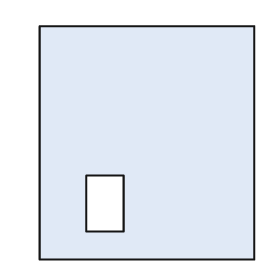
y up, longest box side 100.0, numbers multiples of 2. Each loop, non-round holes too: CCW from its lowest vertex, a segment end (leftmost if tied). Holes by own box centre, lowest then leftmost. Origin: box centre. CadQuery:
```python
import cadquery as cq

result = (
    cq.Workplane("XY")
    .moveTo(-46.0, -50.0)
    .lineTo(46.0, -50.0)
    .lineTo(46.0, 50.0)
    .lineTo(-46.0, 50.0)
    .close()
    .moveTo(-26.0, -38.0)
    .lineTo(-10.0, -38.0)
    .lineTo(-10.0, -14.0)
    .lineTo(-26.0, -14.0)
    .close()
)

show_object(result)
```